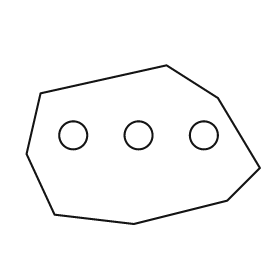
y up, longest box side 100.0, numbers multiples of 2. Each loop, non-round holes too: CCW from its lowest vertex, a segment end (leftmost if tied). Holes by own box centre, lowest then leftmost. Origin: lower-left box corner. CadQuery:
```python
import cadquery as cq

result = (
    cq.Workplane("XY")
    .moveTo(46.0, 0.0)
    .lineTo(86.0, 10.0)
    .lineTo(100.0, 24.0)
    .lineTo(82.0, 54.0)
    .lineTo(60.0, 68.0)
    .lineTo(6.0, 56.0)
    .lineTo(0.0, 30.0)
    .lineTo(12.0, 4.0)
    .close()
    .moveTo(20.0, 38.0)
    .circle(6.0)
    .moveTo(48.0, 38.0)
    .circle(6.0)
    .moveTo(76.0, 38.0)
    .circle(6.0)
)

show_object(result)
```